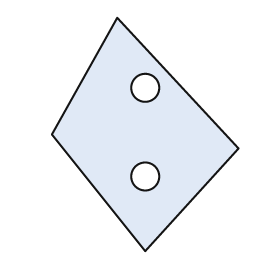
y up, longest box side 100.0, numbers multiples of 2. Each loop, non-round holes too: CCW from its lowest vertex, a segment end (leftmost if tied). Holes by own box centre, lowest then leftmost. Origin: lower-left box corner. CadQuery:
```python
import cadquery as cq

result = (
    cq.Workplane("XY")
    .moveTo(40.0, 0.0)
    .lineTo(80.0, 44.0)
    .lineTo(28.0, 100.0)
    .lineTo(0.0, 50.0)
    .close()
    .moveTo(40.0, 32.0)
    .circle(6.0)
    .moveTo(40.0, 70.0)
    .circle(6.0)
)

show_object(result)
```